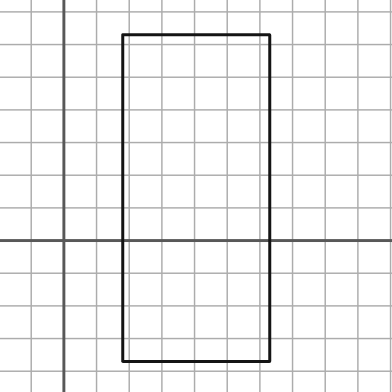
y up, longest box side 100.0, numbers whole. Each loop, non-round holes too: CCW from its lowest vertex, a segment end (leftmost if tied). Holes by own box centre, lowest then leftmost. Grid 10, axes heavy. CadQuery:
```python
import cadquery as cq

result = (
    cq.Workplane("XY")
    .moveTo(18.0, -37.0)
    .lineTo(63.0, -37.0)
    .lineTo(63.0, 63.0)
    .lineTo(18.0, 63.0)
    .close()
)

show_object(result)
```